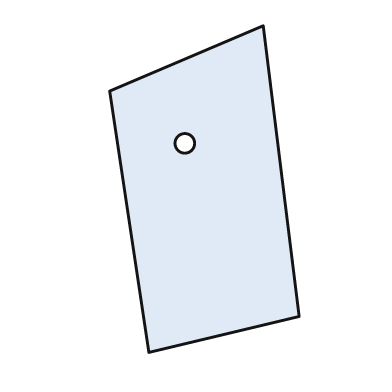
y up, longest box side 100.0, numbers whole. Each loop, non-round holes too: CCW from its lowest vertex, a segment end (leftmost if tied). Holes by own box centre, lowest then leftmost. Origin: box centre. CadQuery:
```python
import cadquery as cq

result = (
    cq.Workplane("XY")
    .moveTo(-17.0, -50.0)
    .lineTo(29.0, -39.0)
    .lineTo(18.0, 50.0)
    .lineTo(-29.0, 30.0)
    .close()
    .moveTo(-6.0, 14.0)
    .circle(3.0)
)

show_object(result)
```